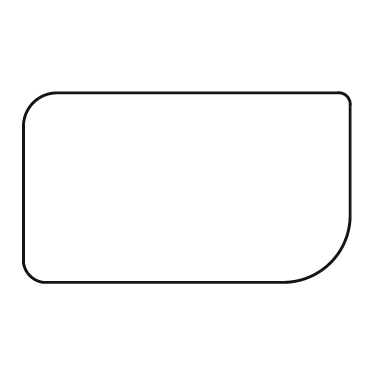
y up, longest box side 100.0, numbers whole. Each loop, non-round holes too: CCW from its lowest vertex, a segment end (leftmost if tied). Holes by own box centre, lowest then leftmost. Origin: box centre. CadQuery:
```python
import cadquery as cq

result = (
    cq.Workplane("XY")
    .moveTo(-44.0, -29.0)
    .lineTo(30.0, -29.0)
    .threePointArc((44.0, -23.0), (50.0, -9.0))
    .lineTo(50.0, 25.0)
    .threePointArc((49.0, 28.0), (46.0, 29.0))
    .lineTo(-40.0, 29.0)
    .threePointArc((-47.0, 26.0), (-50.0, 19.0))
    .lineTo(-50.0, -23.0)
    .threePointArc((-48.0, -27.0), (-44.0, -29.0))
    .close()
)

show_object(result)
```